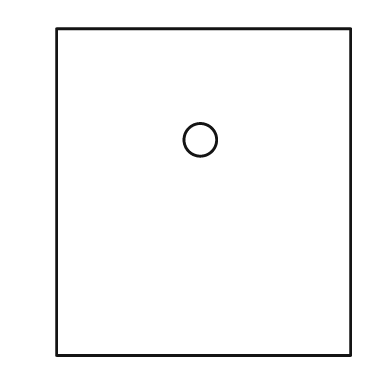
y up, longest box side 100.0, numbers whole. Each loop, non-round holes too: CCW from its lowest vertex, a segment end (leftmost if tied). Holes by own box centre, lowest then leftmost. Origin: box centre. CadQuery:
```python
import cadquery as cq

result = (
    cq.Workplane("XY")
    .moveTo(-45.0, -50.0)
    .lineTo(45.0, -50.0)
    .lineTo(45.0, 50.0)
    .lineTo(-45.0, 50.0)
    .close()
    .moveTo(-1.0, 16.0)
    .circle(5.0)
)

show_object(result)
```